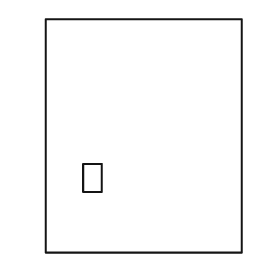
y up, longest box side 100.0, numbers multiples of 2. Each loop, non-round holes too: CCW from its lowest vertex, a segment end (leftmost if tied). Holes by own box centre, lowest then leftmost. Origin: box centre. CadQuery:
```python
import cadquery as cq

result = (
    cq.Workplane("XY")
    .moveTo(-42.0, -50.0)
    .lineTo(42.0, -50.0)
    .lineTo(42.0, 50.0)
    .lineTo(-42.0, 50.0)
    .close()
    .moveTo(-26.0, -24.0)
    .lineTo(-18.0, -24.0)
    .lineTo(-18.0, -12.0)
    .lineTo(-26.0, -12.0)
    .close()
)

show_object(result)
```